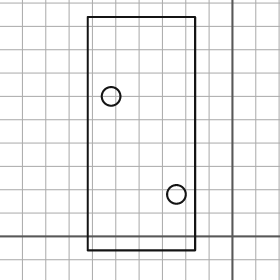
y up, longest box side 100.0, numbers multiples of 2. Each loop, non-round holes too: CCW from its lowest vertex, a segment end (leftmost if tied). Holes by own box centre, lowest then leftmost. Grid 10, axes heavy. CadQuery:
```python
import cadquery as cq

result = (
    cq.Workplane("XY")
    .moveTo(-62.0, -6.0)
    .lineTo(-16.0, -6.0)
    .lineTo(-16.0, 94.0)
    .lineTo(-62.0, 94.0)
    .close()
    .moveTo(-24.0, 18.0)
    .circle(4.0)
    .moveTo(-52.0, 60.0)
    .circle(4.0)
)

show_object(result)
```